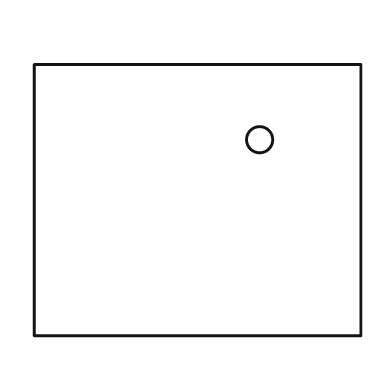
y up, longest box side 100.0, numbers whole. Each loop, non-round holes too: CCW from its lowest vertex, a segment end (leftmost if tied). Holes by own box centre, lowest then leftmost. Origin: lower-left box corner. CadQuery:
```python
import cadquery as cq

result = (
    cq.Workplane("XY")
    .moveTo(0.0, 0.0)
    .lineTo(100.0, 0.0)
    .lineTo(100.0, 83.0)
    .lineTo(0.0, 83.0)
    .close()
    .moveTo(69.0, 60.0)
    .circle(4.0)
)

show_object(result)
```